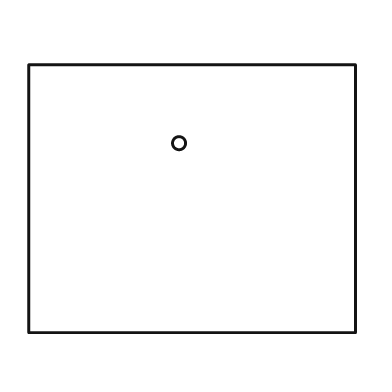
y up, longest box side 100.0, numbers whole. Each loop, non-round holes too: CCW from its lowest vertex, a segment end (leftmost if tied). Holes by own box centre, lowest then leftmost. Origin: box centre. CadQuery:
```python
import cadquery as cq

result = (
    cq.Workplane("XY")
    .moveTo(-50.0, -41.0)
    .lineTo(50.0, -41.0)
    .lineTo(50.0, 41.0)
    .lineTo(-50.0, 41.0)
    .close()
    .moveTo(-4.0, 17.0)
    .circle(2.0)
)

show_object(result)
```